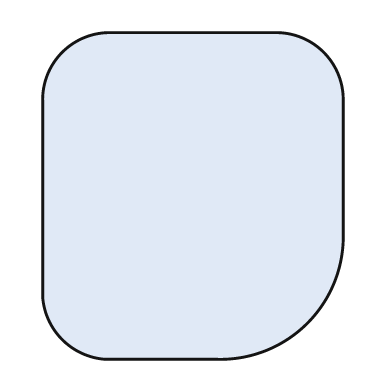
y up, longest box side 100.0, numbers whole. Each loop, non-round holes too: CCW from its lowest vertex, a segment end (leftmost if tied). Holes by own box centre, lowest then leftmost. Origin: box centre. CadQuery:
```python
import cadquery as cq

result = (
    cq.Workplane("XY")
    .moveTo(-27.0, -50.0)
    .lineTo(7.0, -50.0)
    .threePointArc((35.0, -39.0), (46.0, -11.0))
    .lineTo(46.0, 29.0)
    .threePointArc((40.0, 44.0), (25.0, 50.0))
    .lineTo(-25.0, 50.0)
    .threePointArc((-40.0, 44.0), (-46.0, 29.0))
    .lineTo(-46.0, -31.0)
    .threePointArc((-40.0, -44.0), (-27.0, -50.0))
    .close()
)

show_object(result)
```